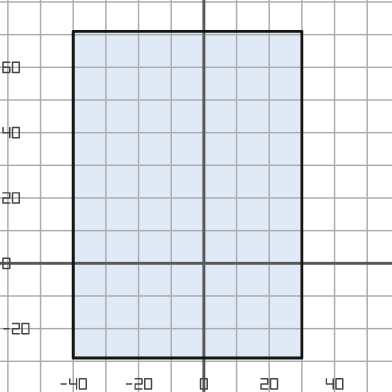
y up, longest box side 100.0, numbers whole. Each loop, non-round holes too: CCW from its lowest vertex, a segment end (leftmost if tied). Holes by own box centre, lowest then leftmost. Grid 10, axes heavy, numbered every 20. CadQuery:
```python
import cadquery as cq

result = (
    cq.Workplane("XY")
    .moveTo(-40.0, -29.0)
    .lineTo(30.0, -29.0)
    .lineTo(30.0, 71.0)
    .lineTo(-40.0, 71.0)
    .close()
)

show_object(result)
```